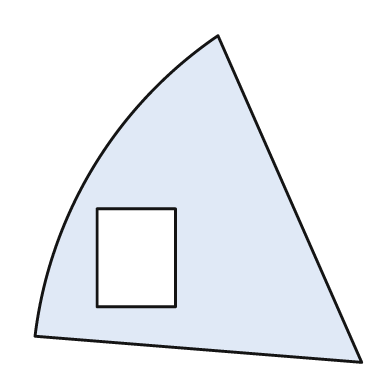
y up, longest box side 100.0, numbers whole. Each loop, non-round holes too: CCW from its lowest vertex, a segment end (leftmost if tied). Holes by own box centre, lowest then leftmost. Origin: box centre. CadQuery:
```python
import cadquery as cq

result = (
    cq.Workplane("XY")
    .moveTo(50.0, -50.0)
    .lineTo(6.0, 50.0)
    .threePointArc((-32.0, 10.0), (-50.0, -42.0))
    .close()
    .moveTo(-31.0, -33.0)
    .lineTo(-7.0, -33.0)
    .lineTo(-7.0, -3.0)
    .lineTo(-31.0, -3.0)
    .close()
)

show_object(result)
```